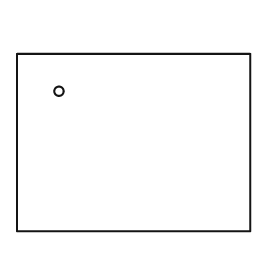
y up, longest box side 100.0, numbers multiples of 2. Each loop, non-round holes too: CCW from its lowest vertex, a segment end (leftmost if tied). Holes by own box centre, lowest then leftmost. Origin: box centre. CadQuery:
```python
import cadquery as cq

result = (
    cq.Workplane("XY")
    .moveTo(-50.0, -38.0)
    .lineTo(50.0, -38.0)
    .lineTo(50.0, 38.0)
    .lineTo(-50.0, 38.0)
    .close()
    .moveTo(-32.0, 22.0)
    .circle(2.0)
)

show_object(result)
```